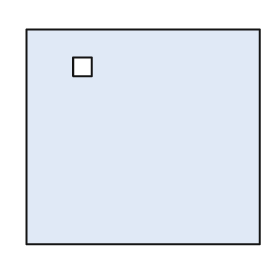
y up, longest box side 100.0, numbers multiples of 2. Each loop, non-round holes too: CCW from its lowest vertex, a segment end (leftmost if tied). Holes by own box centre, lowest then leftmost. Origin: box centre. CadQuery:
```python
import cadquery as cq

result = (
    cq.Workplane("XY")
    .moveTo(-50.0, -46.0)
    .lineTo(50.0, -46.0)
    .lineTo(50.0, 46.0)
    .lineTo(-50.0, 46.0)
    .close()
    .moveTo(-30.0, 26.0)
    .lineTo(-22.0, 26.0)
    .lineTo(-22.0, 34.0)
    .lineTo(-30.0, 34.0)
    .close()
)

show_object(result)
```